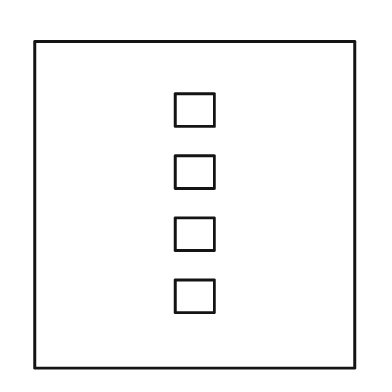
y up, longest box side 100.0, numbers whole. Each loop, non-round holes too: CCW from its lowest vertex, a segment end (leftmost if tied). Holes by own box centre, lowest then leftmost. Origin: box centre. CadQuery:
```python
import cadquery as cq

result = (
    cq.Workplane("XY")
    .moveTo(-49.0, -50.0)
    .lineTo(49.0, -50.0)
    .lineTo(49.0, 50.0)
    .lineTo(-49.0, 50.0)
    .close()
    .moveTo(-6.0, -33.0)
    .lineTo(6.0, -33.0)
    .lineTo(6.0, -23.0)
    .lineTo(-6.0, -23.0)
    .close()
    .moveTo(-6.0, -14.0)
    .lineTo(6.0, -14.0)
    .lineTo(6.0, -4.0)
    .lineTo(-6.0, -4.0)
    .close()
    .moveTo(-6.0, 5.0)
    .lineTo(6.0, 5.0)
    .lineTo(6.0, 15.0)
    .lineTo(-6.0, 15.0)
    .close()
    .moveTo(-6.0, 24.0)
    .lineTo(6.0, 24.0)
    .lineTo(6.0, 34.0)
    .lineTo(-6.0, 34.0)
    .close()
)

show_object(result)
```